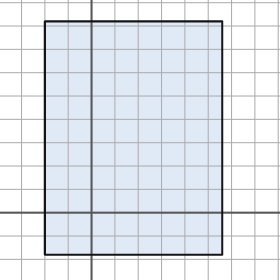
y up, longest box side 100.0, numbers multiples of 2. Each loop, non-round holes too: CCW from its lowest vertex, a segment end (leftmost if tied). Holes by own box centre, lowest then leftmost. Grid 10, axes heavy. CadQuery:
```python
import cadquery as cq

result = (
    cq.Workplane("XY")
    .moveTo(-20.0, -18.0)
    .lineTo(56.0, -18.0)
    .lineTo(56.0, 82.0)
    .lineTo(-20.0, 82.0)
    .close()
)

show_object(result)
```